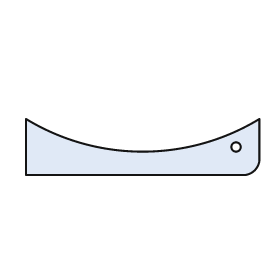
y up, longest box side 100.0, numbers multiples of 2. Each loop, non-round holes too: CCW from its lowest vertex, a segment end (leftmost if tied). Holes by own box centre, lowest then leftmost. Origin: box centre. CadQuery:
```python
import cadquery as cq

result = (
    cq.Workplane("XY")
    .moveTo(-50.0, -12.0)
    .lineTo(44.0, -12.0)
    .threePointArc((48.0, -10.0), (50.0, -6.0))
    .lineTo(50.0, 12.0)
    .threePointArc((0.0, -2.0), (-50.0, 12.0))
    .close()
    .moveTo(40.0, 0.0)
    .circle(2.0)
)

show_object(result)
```